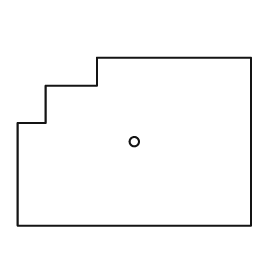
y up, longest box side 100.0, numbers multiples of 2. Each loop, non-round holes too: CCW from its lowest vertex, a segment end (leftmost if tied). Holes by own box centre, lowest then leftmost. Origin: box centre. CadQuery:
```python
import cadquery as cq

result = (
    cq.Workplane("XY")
    .moveTo(-50.0, -36.0)
    .lineTo(50.0, -36.0)
    .lineTo(50.0, 36.0)
    .lineTo(-16.0, 36.0)
    .lineTo(-16.0, 24.0)
    .lineTo(-38.0, 24.0)
    .lineTo(-38.0, 8.0)
    .lineTo(-50.0, 8.0)
    .close()
    .moveTo(0.0, 0.0)
    .circle(2.0)
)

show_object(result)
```